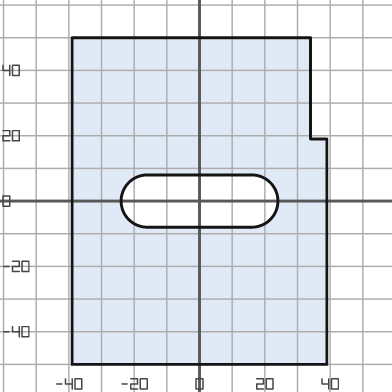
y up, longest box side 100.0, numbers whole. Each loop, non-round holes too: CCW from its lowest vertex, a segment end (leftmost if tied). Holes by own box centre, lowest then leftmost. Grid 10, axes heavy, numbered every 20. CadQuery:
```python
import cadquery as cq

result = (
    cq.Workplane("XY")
    .moveTo(-39.0, -50.0)
    .lineTo(39.0, -50.0)
    .lineTo(39.0, 19.0)
    .lineTo(34.0, 19.0)
    .lineTo(34.0, 50.0)
    .lineTo(-39.0, 50.0)
    .close()
    .moveTo(-16.0, -8.0)
    .lineTo(16.0, -8.0)
    .threePointArc((24.0, 0.0), (16.0, 8.0))
    .lineTo(-16.0, 8.0)
    .threePointArc((-24.0, 0.0), (-16.0, -8.0))
    .close()
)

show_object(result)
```